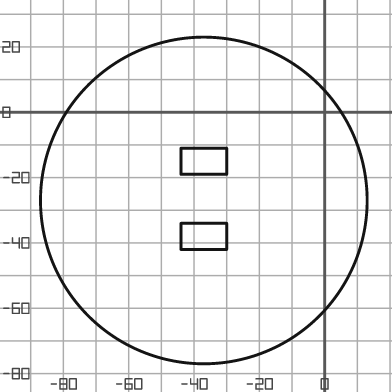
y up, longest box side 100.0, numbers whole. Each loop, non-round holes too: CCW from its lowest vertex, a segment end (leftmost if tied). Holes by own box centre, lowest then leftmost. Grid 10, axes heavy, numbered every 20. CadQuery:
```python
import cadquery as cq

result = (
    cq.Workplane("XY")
    .moveTo(-37.0, -27.0)
    .circle(50.0)
    .moveTo(-44.0, -42.0)
    .lineTo(-30.0, -42.0)
    .lineTo(-30.0, -34.0)
    .lineTo(-44.0, -34.0)
    .close()
    .moveTo(-44.0, -19.0)
    .lineTo(-30.0, -19.0)
    .lineTo(-30.0, -11.0)
    .lineTo(-44.0, -11.0)
    .close()
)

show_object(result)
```